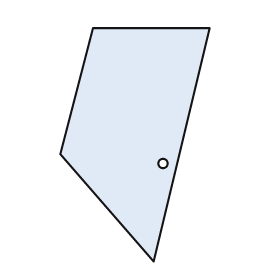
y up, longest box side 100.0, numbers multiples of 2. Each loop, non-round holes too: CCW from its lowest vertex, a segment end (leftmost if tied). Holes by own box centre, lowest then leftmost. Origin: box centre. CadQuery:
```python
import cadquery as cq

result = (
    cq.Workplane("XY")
    .moveTo(8.0, -50.0)
    .lineTo(32.0, 50.0)
    .lineTo(-18.0, 50.0)
    .lineTo(-32.0, -4.0)
    .close()
    .moveTo(12.0, -8.0)
    .circle(2.0)
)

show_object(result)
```